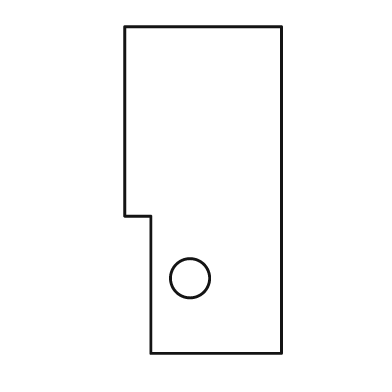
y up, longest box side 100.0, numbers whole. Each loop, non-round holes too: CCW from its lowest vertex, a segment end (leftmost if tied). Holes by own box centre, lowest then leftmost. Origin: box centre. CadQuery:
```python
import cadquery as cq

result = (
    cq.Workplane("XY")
    .moveTo(-16.0, -50.0)
    .lineTo(24.0, -50.0)
    .lineTo(24.0, 50.0)
    .lineTo(-24.0, 50.0)
    .lineTo(-24.0, -8.0)
    .lineTo(-16.0, -8.0)
    .close()
    .moveTo(-4.0, -27.0)
    .circle(6.0)
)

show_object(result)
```